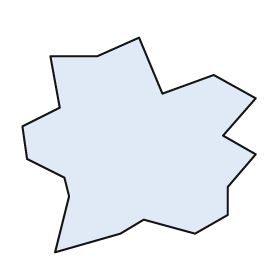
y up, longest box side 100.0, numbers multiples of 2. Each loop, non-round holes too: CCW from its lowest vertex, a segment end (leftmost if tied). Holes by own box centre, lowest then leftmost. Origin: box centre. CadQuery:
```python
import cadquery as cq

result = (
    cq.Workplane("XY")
    .moveTo(-36.0, -46.0)
    .lineTo(-8.0, -38.0)
    .lineTo(2.0, -32.0)
    .lineTo(24.0, -38.0)
    .lineTo(38.0, -30.0)
    .lineTo(38.0, -18.0)
    .lineTo(50.0, -4.0)
    .lineTo(36.0, 4.0)
    .lineTo(50.0, 20.0)
    .lineTo(32.0, 30.0)
    .lineTo(10.0, 22.0)
    .lineTo(0.0, 46.0)
    .lineTo(-18.0, 38.0)
    .lineTo(-38.0, 38.0)
    .lineTo(-34.0, 16.0)
    .lineTo(-50.0, 8.0)
    .lineTo(-48.0, -6.0)
    .lineTo(-32.0, -14.0)
    .lineTo(-30.0, -22.0)
    .close()
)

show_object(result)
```